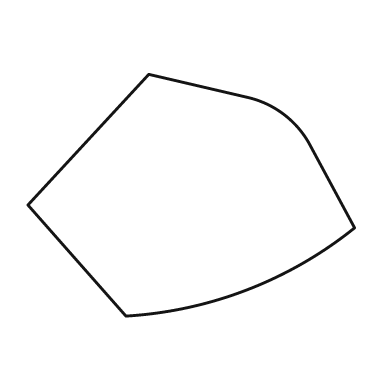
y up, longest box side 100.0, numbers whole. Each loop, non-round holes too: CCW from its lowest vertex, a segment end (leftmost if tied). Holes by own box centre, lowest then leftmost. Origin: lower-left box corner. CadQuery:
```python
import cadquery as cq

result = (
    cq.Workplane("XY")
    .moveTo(30.0, 0.0)
    .threePointArc((67.0, 8.0), (100.0, 27.0))
    .lineTo(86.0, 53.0)
    .threePointArc((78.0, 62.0), (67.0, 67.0))
    .lineTo(37.0, 74.0)
    .lineTo(0.0, 34.0)
    .close()
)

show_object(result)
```